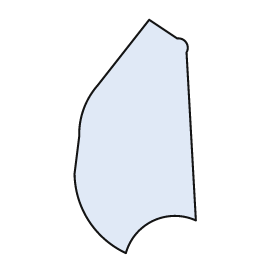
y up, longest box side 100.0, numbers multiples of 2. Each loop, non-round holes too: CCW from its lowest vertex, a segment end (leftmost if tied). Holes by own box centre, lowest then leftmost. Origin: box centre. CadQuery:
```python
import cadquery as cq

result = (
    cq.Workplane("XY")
    .moveTo(-4.0, -50.0)
    .threePointArc((8.0, -36.0), (26.0, -36.0))
    .lineTo(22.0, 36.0)
    .threePointArc((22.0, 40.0), (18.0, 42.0))
    .lineTo(6.0, 50.0)
    .lineTo(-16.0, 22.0)
    .threePointArc((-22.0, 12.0), (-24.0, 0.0))
    .lineTo(-26.0, -16.0)
    .threePointArc((-20.0, -36.0), (-4.0, -50.0))
    .close()
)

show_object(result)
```